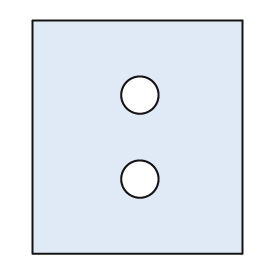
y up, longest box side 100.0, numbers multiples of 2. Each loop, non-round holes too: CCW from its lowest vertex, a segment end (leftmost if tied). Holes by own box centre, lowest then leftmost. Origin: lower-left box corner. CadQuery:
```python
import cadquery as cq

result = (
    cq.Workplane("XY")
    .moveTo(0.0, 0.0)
    .lineTo(90.0, 0.0)
    .lineTo(90.0, 100.0)
    .lineTo(0.0, 100.0)
    .close()
    .moveTo(46.0, 32.0)
    .circle(8.0)
    .moveTo(46.0, 68.0)
    .circle(8.0)
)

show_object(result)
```